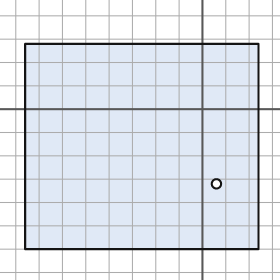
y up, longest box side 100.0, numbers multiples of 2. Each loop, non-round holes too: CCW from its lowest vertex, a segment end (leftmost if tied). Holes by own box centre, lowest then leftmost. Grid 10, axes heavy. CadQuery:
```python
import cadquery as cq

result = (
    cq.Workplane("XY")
    .moveTo(-76.0, -60.0)
    .lineTo(24.0, -60.0)
    .lineTo(24.0, 28.0)
    .lineTo(-76.0, 28.0)
    .close()
    .moveTo(6.0, -32.0)
    .circle(2.0)
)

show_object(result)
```